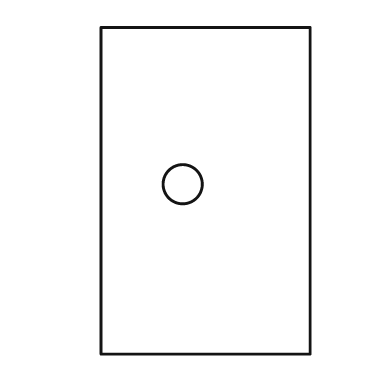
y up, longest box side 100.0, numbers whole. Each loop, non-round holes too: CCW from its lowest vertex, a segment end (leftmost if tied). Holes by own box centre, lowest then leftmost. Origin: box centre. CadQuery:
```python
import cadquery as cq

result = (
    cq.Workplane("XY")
    .moveTo(-32.0, -50.0)
    .lineTo(32.0, -50.0)
    .lineTo(32.0, 50.0)
    .lineTo(-32.0, 50.0)
    .close()
    .moveTo(-7.0, 2.0)
    .circle(6.0)
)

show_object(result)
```